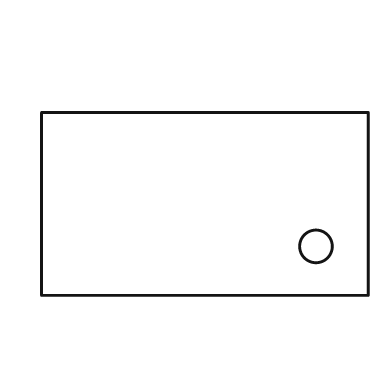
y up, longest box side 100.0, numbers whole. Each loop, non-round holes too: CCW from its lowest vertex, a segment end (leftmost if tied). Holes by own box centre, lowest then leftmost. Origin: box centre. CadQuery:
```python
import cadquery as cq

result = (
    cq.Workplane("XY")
    .moveTo(-50.0, -28.0)
    .lineTo(50.0, -28.0)
    .lineTo(50.0, 28.0)
    .lineTo(-50.0, 28.0)
    .close()
    .moveTo(34.0, -13.0)
    .circle(5.0)
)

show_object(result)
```